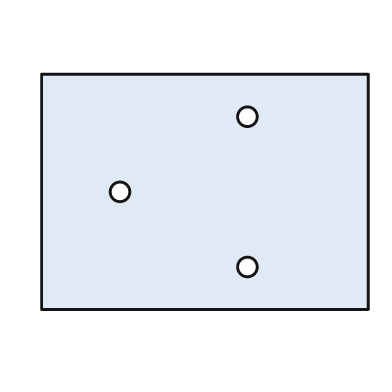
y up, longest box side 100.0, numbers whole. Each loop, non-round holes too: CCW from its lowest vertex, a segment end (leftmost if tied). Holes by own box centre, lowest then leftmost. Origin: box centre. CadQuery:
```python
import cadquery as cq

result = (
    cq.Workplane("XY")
    .moveTo(-50.0, -36.0)
    .lineTo(50.0, -36.0)
    .lineTo(50.0, 36.0)
    .lineTo(-50.0, 36.0)
    .close()
    .moveTo(13.0, -23.0)
    .circle(3.0)
    .moveTo(-26.0, 0.0)
    .circle(3.0)
    .moveTo(13.0, 23.0)
    .circle(3.0)
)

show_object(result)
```